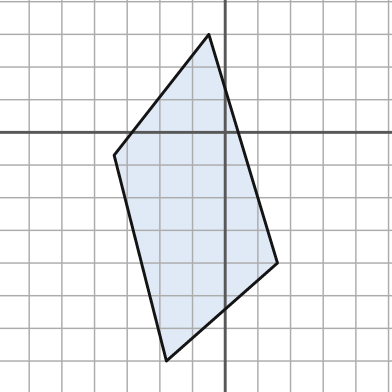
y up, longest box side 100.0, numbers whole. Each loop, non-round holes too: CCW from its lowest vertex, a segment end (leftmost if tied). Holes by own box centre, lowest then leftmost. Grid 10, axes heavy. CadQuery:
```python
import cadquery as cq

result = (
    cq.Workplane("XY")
    .moveTo(-18.0, -70.0)
    .lineTo(16.0, -40.0)
    .lineTo(-5.0, 30.0)
    .lineTo(-34.0, -7.0)
    .close()
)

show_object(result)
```